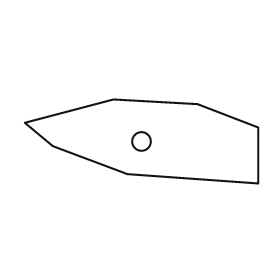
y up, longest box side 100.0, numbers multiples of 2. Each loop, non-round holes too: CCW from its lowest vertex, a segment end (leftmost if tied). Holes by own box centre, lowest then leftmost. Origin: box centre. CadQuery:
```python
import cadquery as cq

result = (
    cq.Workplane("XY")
    .moveTo(50.0, -18.0)
    .lineTo(50.0, 6.0)
    .lineTo(24.0, 16.0)
    .lineTo(-12.0, 18.0)
    .lineTo(-50.0, 8.0)
    .lineTo(-38.0, -2.0)
    .lineTo(-6.0, -14.0)
    .close()
    .moveTo(0.0, 0.0)
    .circle(4.0)
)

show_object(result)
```